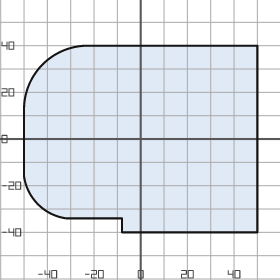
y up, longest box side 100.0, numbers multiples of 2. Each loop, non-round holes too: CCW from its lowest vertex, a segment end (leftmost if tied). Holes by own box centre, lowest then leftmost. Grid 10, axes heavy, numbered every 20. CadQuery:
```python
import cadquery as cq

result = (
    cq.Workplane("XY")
    .moveTo(-8.0, -40.0)
    .lineTo(50.0, -40.0)
    .lineTo(50.0, 40.0)
    .lineTo(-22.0, 40.0)
    .threePointArc((-42.0, 32.0), (-50.0, 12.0))
    .lineTo(-50.0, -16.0)
    .threePointArc((-44.0, -28.0), (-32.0, -34.0))
    .lineTo(-8.0, -34.0)
    .close()
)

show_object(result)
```